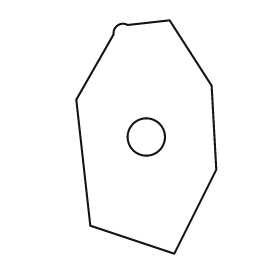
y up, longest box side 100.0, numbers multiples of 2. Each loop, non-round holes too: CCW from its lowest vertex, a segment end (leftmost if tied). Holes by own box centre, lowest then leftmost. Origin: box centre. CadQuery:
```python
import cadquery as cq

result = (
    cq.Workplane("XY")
    .moveTo(12.0, -50.0)
    .lineTo(30.0, -14.0)
    .lineTo(28.0, 22.0)
    .lineTo(10.0, 50.0)
    .lineTo(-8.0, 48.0)
    .threePointArc((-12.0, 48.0), (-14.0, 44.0))
    .lineTo(-30.0, 16.0)
    .lineTo(-24.0, -38.0)
    .close()
    .moveTo(0.0, 0.0)
    .circle(8.0)
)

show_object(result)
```